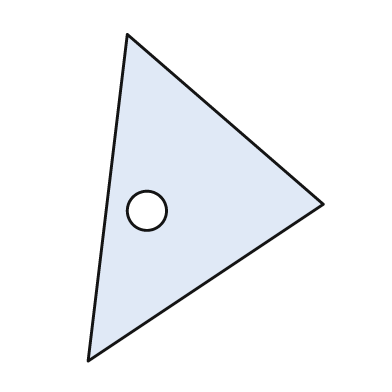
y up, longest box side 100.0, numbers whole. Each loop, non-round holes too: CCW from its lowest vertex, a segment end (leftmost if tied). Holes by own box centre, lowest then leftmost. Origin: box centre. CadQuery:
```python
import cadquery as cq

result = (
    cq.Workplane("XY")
    .moveTo(-36.0, -50.0)
    .lineTo(36.0, -2.0)
    .lineTo(-24.0, 50.0)
    .close()
    .moveTo(-18.0, -4.0)
    .circle(6.0)
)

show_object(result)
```